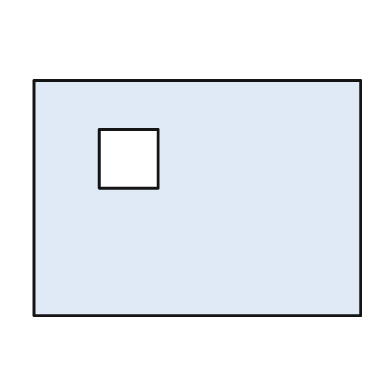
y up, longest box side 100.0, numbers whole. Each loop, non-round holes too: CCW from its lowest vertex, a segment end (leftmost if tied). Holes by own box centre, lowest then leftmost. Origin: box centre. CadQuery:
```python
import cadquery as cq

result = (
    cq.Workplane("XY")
    .moveTo(-50.0, -36.0)
    .lineTo(50.0, -36.0)
    .lineTo(50.0, 36.0)
    .lineTo(-50.0, 36.0)
    .close()
    .moveTo(-30.0, 3.0)
    .lineTo(-12.0, 3.0)
    .lineTo(-12.0, 21.0)
    .lineTo(-30.0, 21.0)
    .close()
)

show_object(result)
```